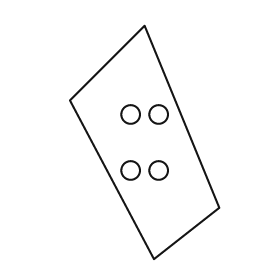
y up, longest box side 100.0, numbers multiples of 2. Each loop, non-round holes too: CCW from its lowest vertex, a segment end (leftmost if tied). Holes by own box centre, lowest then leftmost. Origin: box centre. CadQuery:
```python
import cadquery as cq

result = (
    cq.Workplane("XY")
    .moveTo(4.0, -50.0)
    .lineTo(32.0, -28.0)
    .lineTo(0.0, 50.0)
    .lineTo(-32.0, 18.0)
    .close()
    .moveTo(-6.0, -12.0)
    .circle(4.0)
    .moveTo(6.0, -12.0)
    .circle(4.0)
    .moveTo(-6.0, 12.0)
    .circle(4.0)
    .moveTo(6.0, 12.0)
    .circle(4.0)
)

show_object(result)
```